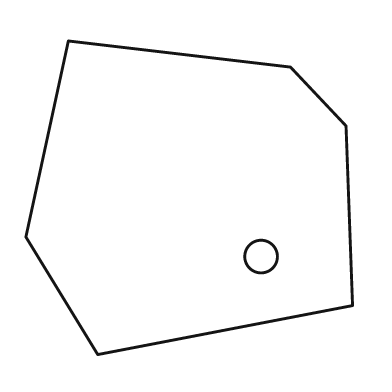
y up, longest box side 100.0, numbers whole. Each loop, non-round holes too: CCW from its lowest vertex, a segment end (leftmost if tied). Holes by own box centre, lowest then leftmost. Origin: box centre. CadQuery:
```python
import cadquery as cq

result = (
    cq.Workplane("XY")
    .moveTo(-28.0, -48.0)
    .lineTo(50.0, -33.0)
    .lineTo(48.0, 22.0)
    .lineTo(31.0, 40.0)
    .lineTo(-37.0, 48.0)
    .lineTo(-50.0, -12.0)
    .close()
    .moveTo(22.0, -18.0)
    .circle(5.0)
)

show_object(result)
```